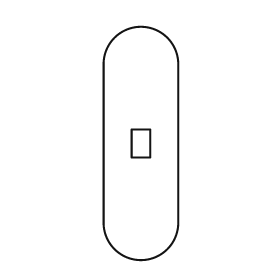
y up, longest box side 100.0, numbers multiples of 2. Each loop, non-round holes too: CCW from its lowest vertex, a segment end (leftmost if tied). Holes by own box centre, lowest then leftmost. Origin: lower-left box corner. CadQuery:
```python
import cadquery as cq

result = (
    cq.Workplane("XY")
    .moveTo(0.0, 16.0)
    .threePointArc((16.0, 0.0), (32.0, 16.0))
    .lineTo(32.0, 84.0)
    .threePointArc((16.0, 100.0), (0.0, 84.0))
    .close()
    .moveTo(12.0, 44.0)
    .lineTo(20.0, 44.0)
    .lineTo(20.0, 56.0)
    .lineTo(12.0, 56.0)
    .close()
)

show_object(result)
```